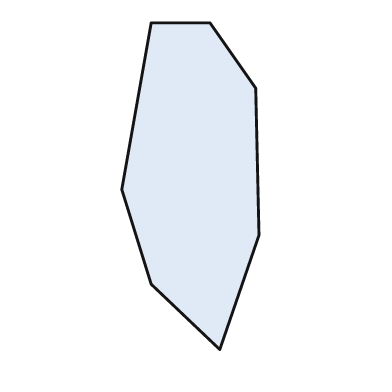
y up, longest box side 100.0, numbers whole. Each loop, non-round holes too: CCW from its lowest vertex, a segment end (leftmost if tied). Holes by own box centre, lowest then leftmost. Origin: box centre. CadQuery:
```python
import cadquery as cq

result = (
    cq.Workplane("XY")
    .moveTo(9.0, -50.0)
    .lineTo(21.0, -15.0)
    .lineTo(20.0, 30.0)
    .lineTo(6.0, 50.0)
    .lineTo(-12.0, 50.0)
    .lineTo(-21.0, -1.0)
    .lineTo(-12.0, -30.0)
    .close()
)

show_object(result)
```